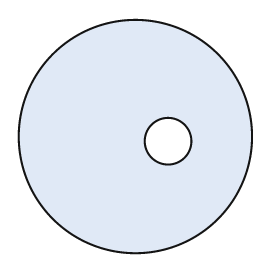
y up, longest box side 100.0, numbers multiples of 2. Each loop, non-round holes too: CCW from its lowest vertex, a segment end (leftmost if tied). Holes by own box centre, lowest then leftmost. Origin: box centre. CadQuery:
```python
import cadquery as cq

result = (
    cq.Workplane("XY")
    .moveTo(0.0, 0.0)
    .circle(50.0)
    .moveTo(14.0, -2.0)
    .circle(10.0)
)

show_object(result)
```